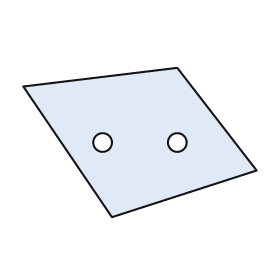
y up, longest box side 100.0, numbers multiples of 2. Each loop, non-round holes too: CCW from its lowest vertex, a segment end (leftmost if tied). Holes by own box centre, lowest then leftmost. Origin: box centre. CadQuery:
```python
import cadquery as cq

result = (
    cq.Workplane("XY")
    .moveTo(-12.0, -32.0)
    .lineTo(50.0, -12.0)
    .lineTo(16.0, 32.0)
    .lineTo(-50.0, 24.0)
    .close()
    .moveTo(-16.0, 0.0)
    .circle(4.0)
    .moveTo(16.0, 0.0)
    .circle(4.0)
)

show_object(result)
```